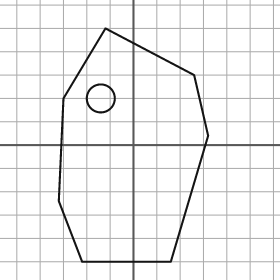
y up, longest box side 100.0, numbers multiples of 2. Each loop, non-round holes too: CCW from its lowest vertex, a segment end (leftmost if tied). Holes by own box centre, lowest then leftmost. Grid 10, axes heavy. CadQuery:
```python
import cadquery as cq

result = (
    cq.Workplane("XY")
    .moveTo(-22.0, -50.0)
    .lineTo(16.0, -50.0)
    .lineTo(32.0, 4.0)
    .lineTo(26.0, 30.0)
    .lineTo(-12.0, 50.0)
    .lineTo(-30.0, 20.0)
    .lineTo(-32.0, -24.0)
    .close()
    .moveTo(-14.0, 20.0)
    .circle(6.0)
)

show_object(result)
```